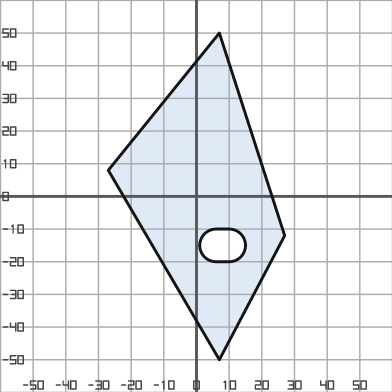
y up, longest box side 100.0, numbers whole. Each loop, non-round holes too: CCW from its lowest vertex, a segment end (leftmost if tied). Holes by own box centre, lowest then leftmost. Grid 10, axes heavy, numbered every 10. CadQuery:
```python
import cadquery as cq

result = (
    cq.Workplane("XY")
    .moveTo(7.0, -50.0)
    .lineTo(27.0, -12.0)
    .lineTo(7.0, 50.0)
    .lineTo(-27.0, 8.0)
    .close()
    .moveTo(6.0, -20.0)
    .lineTo(10.0, -20.0)
    .threePointArc((15.0, -15.0), (10.0, -10.0))
    .lineTo(6.0, -10.0)
    .threePointArc((1.0, -15.0), (6.0, -20.0))
    .close()
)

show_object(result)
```